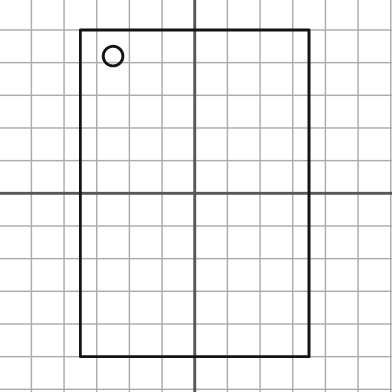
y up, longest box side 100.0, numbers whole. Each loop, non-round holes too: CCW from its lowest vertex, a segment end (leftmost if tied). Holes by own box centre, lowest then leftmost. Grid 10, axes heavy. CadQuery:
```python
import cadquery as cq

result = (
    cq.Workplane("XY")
    .moveTo(-35.0, -50.0)
    .lineTo(35.0, -50.0)
    .lineTo(35.0, 50.0)
    .lineTo(-35.0, 50.0)
    .close()
    .moveTo(-25.0, 42.0)
    .circle(3.0)
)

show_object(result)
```